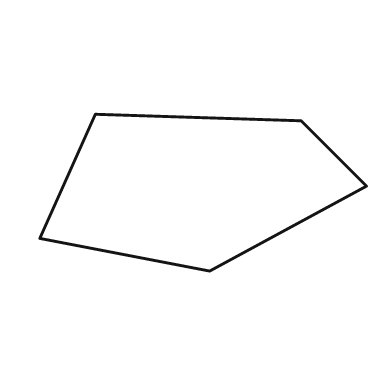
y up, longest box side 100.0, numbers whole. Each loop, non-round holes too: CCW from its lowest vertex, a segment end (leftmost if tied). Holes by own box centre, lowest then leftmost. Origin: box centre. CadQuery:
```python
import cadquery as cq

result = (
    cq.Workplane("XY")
    .moveTo(2.0, -24.0)
    .lineTo(50.0, 2.0)
    .lineTo(30.0, 22.0)
    .lineTo(-33.0, 24.0)
    .lineTo(-50.0, -14.0)
    .close()
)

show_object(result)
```